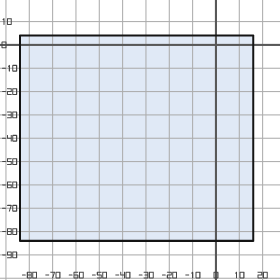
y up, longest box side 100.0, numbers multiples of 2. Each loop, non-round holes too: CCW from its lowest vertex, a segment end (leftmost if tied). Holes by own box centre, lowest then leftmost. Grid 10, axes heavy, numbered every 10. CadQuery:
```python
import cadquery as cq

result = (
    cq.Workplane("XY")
    .moveTo(-84.0, -84.0)
    .lineTo(16.0, -84.0)
    .lineTo(16.0, 4.0)
    .lineTo(-84.0, 4.0)
    .close()
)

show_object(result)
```